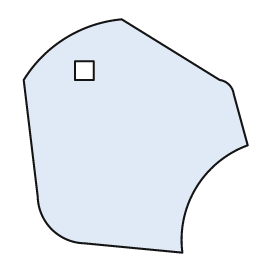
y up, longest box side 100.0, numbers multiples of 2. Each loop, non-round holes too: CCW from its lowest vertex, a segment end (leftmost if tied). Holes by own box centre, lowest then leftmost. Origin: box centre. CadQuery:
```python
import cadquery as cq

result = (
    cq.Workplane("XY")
    .moveTo(20.0, -50.0)
    .threePointArc((26.0, -22.0), (48.0, -4.0))
    .lineTo(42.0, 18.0)
    .threePointArc((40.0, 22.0), (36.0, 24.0))
    .lineTo(-6.0, 50.0)
    .threePointArc((-30.0, 42.0), (-48.0, 24.0))
    .lineTo(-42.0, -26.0)
    .threePointArc((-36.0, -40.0), (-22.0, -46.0))
    .close()
    .moveTo(-26.0, 24.0)
    .lineTo(-18.0, 24.0)
    .lineTo(-18.0, 32.0)
    .lineTo(-26.0, 32.0)
    .close()
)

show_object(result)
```